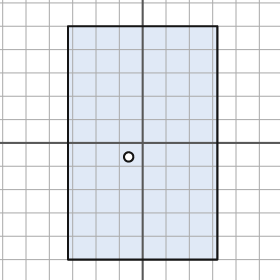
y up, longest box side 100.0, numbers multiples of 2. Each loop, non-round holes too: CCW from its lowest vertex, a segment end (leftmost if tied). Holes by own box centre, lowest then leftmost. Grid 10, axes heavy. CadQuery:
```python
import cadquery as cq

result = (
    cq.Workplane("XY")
    .moveTo(-32.0, -50.0)
    .lineTo(32.0, -50.0)
    .lineTo(32.0, 50.0)
    .lineTo(-32.0, 50.0)
    .close()
    .moveTo(-6.0, -6.0)
    .circle(2.0)
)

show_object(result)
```